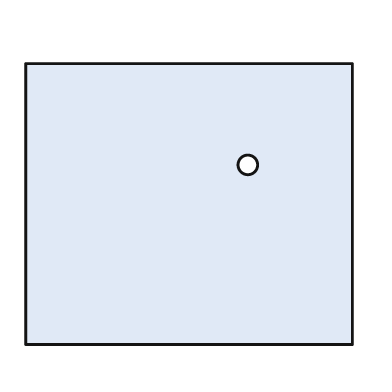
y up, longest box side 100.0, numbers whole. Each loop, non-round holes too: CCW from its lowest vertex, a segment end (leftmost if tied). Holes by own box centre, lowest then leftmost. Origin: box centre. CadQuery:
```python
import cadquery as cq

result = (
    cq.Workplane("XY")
    .moveTo(-50.0, -43.0)
    .lineTo(50.0, -43.0)
    .lineTo(50.0, 43.0)
    .lineTo(-50.0, 43.0)
    .close()
    .moveTo(18.0, 12.0)
    .circle(3.0)
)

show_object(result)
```